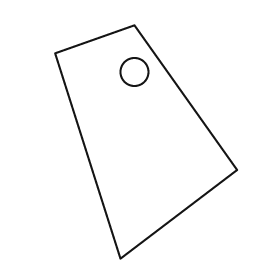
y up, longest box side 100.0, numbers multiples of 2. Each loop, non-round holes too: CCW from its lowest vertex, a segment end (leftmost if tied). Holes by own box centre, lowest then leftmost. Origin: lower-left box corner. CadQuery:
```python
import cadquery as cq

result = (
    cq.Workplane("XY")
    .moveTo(28.0, 0.0)
    .lineTo(78.0, 38.0)
    .lineTo(34.0, 100.0)
    .lineTo(0.0, 88.0)
    .close()
    .moveTo(34.0, 80.0)
    .circle(6.0)
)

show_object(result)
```